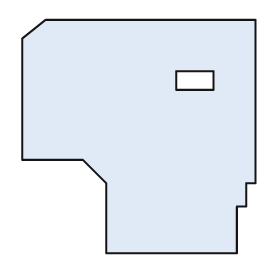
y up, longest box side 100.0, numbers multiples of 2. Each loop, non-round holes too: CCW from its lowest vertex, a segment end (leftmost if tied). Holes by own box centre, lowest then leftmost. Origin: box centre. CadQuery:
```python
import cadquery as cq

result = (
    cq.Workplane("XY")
    .moveTo(-14.0, -50.0)
    .lineTo(42.0, -50.0)
    .lineTo(42.0, -30.0)
    .lineTo(46.0, -30.0)
    .lineTo(46.0, -20.0)
    .lineTo(50.0, -20.0)
    .lineTo(50.0, 50.0)
    .lineTo(-40.0, 50.0)
    .lineTo(-50.0, 42.0)
    .lineTo(-50.0, -10.0)
    .lineTo(-24.0, -10.0)
    .lineTo(-14.0, -20.0)
    .close()
    .moveTo(16.0, 20.0)
    .lineTo(32.0, 20.0)
    .lineTo(32.0, 28.0)
    .lineTo(16.0, 28.0)
    .close()
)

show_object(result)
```